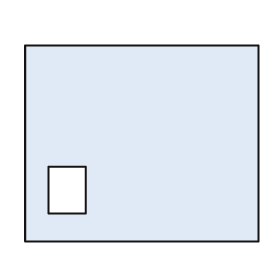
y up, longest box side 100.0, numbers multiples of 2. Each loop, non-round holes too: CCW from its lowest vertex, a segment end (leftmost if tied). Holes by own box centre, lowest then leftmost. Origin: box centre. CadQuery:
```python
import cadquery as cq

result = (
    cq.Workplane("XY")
    .moveTo(-50.0, -42.0)
    .lineTo(50.0, -42.0)
    .lineTo(50.0, 42.0)
    .lineTo(-50.0, 42.0)
    .close()
    .moveTo(-40.0, -30.0)
    .lineTo(-24.0, -30.0)
    .lineTo(-24.0, -10.0)
    .lineTo(-40.0, -10.0)
    .close()
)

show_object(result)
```